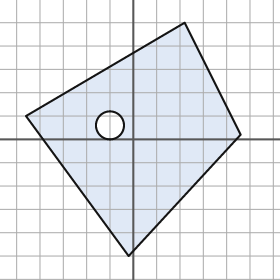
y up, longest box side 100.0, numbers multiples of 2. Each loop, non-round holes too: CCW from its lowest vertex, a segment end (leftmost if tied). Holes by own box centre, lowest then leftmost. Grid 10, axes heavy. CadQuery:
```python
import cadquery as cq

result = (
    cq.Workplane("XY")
    .moveTo(-2.0, -50.0)
    .lineTo(46.0, 2.0)
    .lineTo(22.0, 50.0)
    .lineTo(-46.0, 10.0)
    .close()
    .moveTo(-10.0, 6.0)
    .circle(6.0)
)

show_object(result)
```